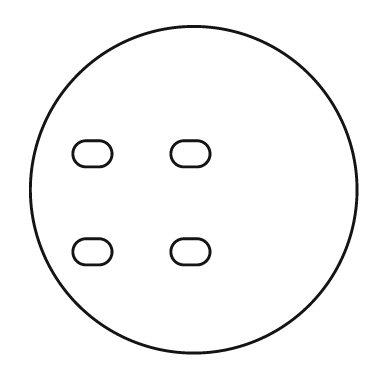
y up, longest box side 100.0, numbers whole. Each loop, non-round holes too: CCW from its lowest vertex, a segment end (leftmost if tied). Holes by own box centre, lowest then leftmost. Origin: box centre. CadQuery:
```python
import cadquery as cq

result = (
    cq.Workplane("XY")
    .moveTo(0.0, 0.0)
    .circle(50.0)
    .moveTo(-33.0, -23.0)
    .lineTo(-29.0, -23.0)
    .threePointArc((-25.0, -19.0), (-29.0, -15.0))
    .lineTo(-33.0, -15.0)
    .threePointArc((-37.0, -19.0), (-33.0, -23.0))
    .close()
    .moveTo(-3.0, -23.0)
    .lineTo(1.0, -23.0)
    .threePointArc((5.0, -19.0), (1.0, -15.0))
    .lineTo(-3.0, -15.0)
    .threePointArc((-7.0, -19.0), (-3.0, -23.0))
    .close()
    .moveTo(-33.0, 7.0)
    .lineTo(-29.0, 7.0)
    .threePointArc((-25.0, 11.0), (-29.0, 15.0))
    .lineTo(-33.0, 15.0)
    .threePointArc((-37.0, 11.0), (-33.0, 7.0))
    .close()
    .moveTo(-3.0, 7.0)
    .lineTo(1.0, 7.0)
    .threePointArc((5.0, 11.0), (1.0, 15.0))
    .lineTo(-3.0, 15.0)
    .threePointArc((-7.0, 11.0), (-3.0, 7.0))
    .close()
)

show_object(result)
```